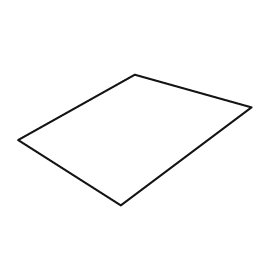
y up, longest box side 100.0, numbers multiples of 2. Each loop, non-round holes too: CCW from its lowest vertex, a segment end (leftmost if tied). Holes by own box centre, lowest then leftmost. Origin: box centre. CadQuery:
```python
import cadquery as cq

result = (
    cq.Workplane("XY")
    .moveTo(-6.0, -28.0)
    .lineTo(50.0, 14.0)
    .lineTo(0.0, 28.0)
    .lineTo(-50.0, 0.0)
    .close()
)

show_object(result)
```